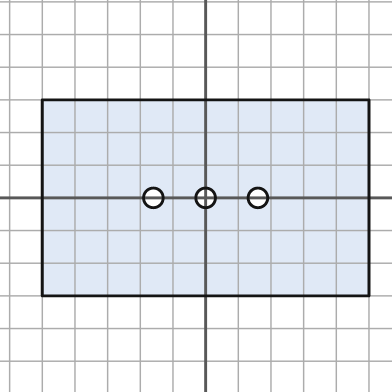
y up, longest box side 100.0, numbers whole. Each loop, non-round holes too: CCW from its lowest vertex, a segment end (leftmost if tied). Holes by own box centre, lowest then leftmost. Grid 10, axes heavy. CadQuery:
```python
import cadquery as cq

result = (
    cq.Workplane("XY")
    .moveTo(-50.0, -30.0)
    .lineTo(50.0, -30.0)
    .lineTo(50.0, 30.0)
    .lineTo(-50.0, 30.0)
    .close()
    .moveTo(-16.0, 0.0)
    .circle(3.0)
    .moveTo(0.0, 0.0)
    .circle(3.0)
    .moveTo(16.0, 0.0)
    .circle(3.0)
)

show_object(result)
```